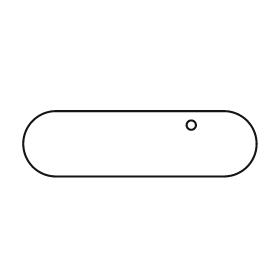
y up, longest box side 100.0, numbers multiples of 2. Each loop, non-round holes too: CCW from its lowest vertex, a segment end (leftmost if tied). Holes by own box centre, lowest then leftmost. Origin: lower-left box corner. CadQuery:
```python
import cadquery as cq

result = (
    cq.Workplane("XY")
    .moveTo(14.0, 0.0)
    .lineTo(86.0, 0.0)
    .threePointArc((100.0, 14.0), (86.0, 28.0))
    .lineTo(14.0, 28.0)
    .threePointArc((0.0, 14.0), (14.0, 0.0))
    .close()
    .moveTo(72.0, 22.0)
    .circle(2.0)
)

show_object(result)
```